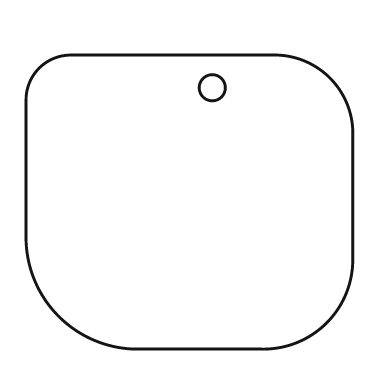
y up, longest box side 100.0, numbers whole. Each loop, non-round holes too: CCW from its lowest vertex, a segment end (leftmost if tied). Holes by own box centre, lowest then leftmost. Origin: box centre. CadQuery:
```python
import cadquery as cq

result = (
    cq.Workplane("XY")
    .moveTo(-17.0, -45.0)
    .lineTo(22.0, -45.0)
    .threePointArc((42.0, -37.0), (50.0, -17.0))
    .lineTo(50.0, 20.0)
    .threePointArc((43.0, 38.0), (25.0, 45.0))
    .lineTo(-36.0, 45.0)
    .threePointArc((-46.0, 41.0), (-50.0, 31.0))
    .lineTo(-50.0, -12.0)
    .threePointArc((-40.0, -35.0), (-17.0, -45.0))
    .close()
    .moveTo(7.0, 35.0)
    .circle(4.0)
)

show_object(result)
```